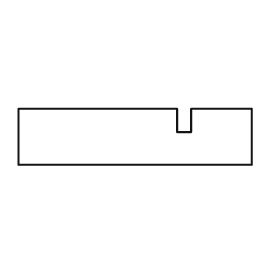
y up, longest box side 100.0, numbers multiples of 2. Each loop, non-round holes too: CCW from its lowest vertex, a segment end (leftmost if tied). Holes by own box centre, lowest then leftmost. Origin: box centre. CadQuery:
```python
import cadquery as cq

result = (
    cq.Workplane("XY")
    .moveTo(-50.0, -12.0)
    .lineTo(50.0, -12.0)
    .lineTo(50.0, 12.0)
    .lineTo(24.0, 12.0)
    .lineTo(24.0, 2.0)
    .lineTo(18.0, 2.0)
    .lineTo(18.0, 12.0)
    .lineTo(-50.0, 12.0)
    .close()
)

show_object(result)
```